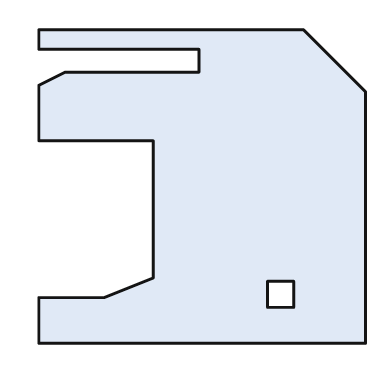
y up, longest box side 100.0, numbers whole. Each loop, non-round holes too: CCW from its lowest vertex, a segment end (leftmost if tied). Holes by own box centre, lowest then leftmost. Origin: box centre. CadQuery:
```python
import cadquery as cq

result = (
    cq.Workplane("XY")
    .moveTo(-50.0, -48.0)
    .lineTo(50.0, -48.0)
    .lineTo(50.0, 29.0)
    .lineTo(31.0, 48.0)
    .lineTo(-50.0, 48.0)
    .lineTo(-50.0, 42.0)
    .lineTo(-1.0, 42.0)
    .lineTo(-1.0, 35.0)
    .lineTo(-42.0, 35.0)
    .lineTo(-50.0, 31.0)
    .lineTo(-50.0, 14.0)
    .lineTo(-15.0, 14.0)
    .lineTo(-15.0, -28.0)
    .lineTo(-30.0, -34.0)
    .lineTo(-50.0, -34.0)
    .close()
    .moveTo(20.0, -37.0)
    .lineTo(28.0, -37.0)
    .lineTo(28.0, -29.0)
    .lineTo(20.0, -29.0)
    .close()
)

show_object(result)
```